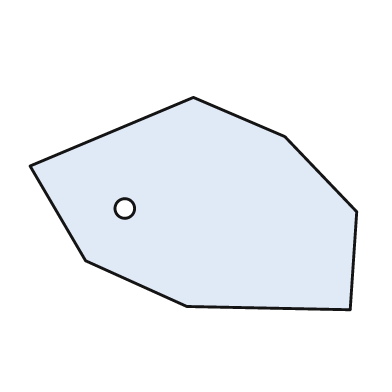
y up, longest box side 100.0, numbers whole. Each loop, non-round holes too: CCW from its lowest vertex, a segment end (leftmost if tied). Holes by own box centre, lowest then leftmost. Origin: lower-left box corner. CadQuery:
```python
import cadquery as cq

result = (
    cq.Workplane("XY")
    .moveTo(98.0, 0.0)
    .lineTo(100.0, 30.0)
    .lineTo(78.0, 53.0)
    .lineTo(50.0, 65.0)
    .lineTo(0.0, 44.0)
    .lineTo(17.0, 15.0)
    .lineTo(48.0, 1.0)
    .close()
    .moveTo(29.0, 31.0)
    .circle(3.0)
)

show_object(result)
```